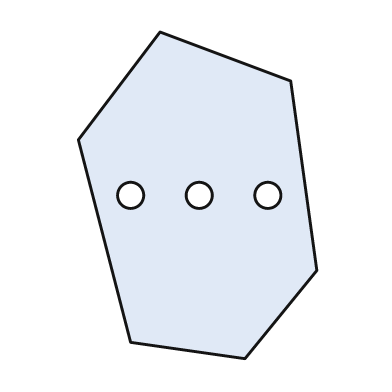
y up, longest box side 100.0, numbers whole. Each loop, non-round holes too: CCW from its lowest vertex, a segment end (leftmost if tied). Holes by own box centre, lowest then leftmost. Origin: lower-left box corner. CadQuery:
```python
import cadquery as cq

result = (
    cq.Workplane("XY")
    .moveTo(51.0, 0.0)
    .lineTo(73.0, 27.0)
    .lineTo(65.0, 85.0)
    .lineTo(25.0, 100.0)
    .lineTo(0.0, 67.0)
    .lineTo(16.0, 5.0)
    .close()
    .moveTo(16.0, 50.0)
    .circle(4.0)
    .moveTo(37.0, 50.0)
    .circle(4.0)
    .moveTo(58.0, 50.0)
    .circle(4.0)
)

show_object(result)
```